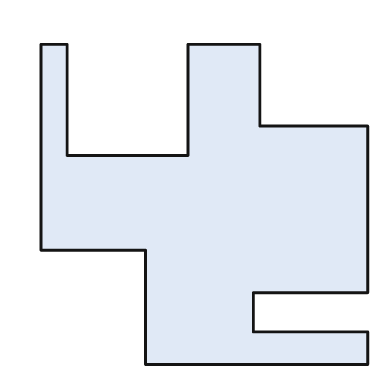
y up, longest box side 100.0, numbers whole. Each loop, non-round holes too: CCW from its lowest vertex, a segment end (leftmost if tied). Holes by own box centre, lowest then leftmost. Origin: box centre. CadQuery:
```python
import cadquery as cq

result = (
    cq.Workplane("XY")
    .moveTo(-18.0, -49.0)
    .lineTo(50.0, -49.0)
    .lineTo(50.0, -39.0)
    .lineTo(15.0, -39.0)
    .lineTo(15.0, -27.0)
    .lineTo(50.0, -27.0)
    .lineTo(50.0, 24.0)
    .lineTo(17.0, 24.0)
    .lineTo(17.0, 49.0)
    .lineTo(-5.0, 49.0)
    .lineTo(-5.0, 15.0)
    .lineTo(-42.0, 15.0)
    .lineTo(-42.0, 49.0)
    .lineTo(-50.0, 49.0)
    .lineTo(-50.0, -14.0)
    .lineTo(-18.0, -14.0)
    .close()
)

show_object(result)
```